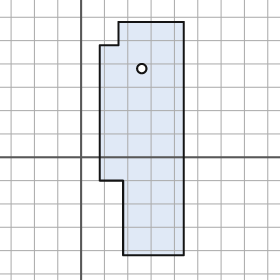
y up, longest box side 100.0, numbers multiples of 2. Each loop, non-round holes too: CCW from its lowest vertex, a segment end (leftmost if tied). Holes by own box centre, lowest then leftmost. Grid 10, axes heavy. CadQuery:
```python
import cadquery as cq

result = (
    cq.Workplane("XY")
    .moveTo(18.0, -42.0)
    .lineTo(44.0, -42.0)
    .lineTo(44.0, 58.0)
    .lineTo(16.0, 58.0)
    .lineTo(16.0, 48.0)
    .lineTo(8.0, 48.0)
    .lineTo(8.0, -10.0)
    .lineTo(18.0, -10.0)
    .close()
    .moveTo(26.0, 38.0)
    .circle(2.0)
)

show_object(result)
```